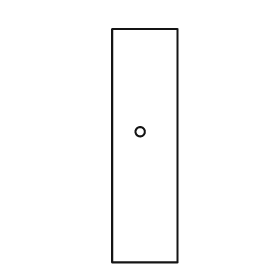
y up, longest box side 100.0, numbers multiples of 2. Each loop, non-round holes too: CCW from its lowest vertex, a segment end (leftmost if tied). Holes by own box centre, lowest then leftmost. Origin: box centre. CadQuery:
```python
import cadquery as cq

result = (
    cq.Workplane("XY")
    .moveTo(-14.0, -50.0)
    .lineTo(14.0, -50.0)
    .lineTo(14.0, 50.0)
    .lineTo(-14.0, 50.0)
    .close()
    .moveTo(-2.0, 6.0)
    .circle(2.0)
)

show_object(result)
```